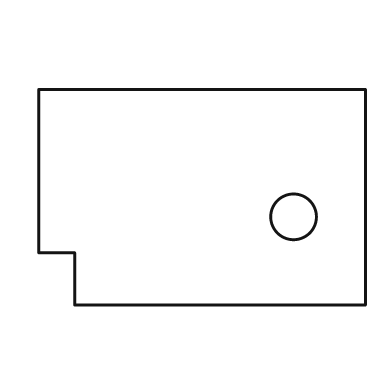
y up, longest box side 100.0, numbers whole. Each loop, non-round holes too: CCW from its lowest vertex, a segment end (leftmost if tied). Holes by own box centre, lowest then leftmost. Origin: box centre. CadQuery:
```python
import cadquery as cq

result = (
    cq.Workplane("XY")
    .moveTo(-39.0, -33.0)
    .lineTo(50.0, -33.0)
    .lineTo(50.0, 33.0)
    .lineTo(-50.0, 33.0)
    .lineTo(-50.0, -17.0)
    .lineTo(-39.0, -17.0)
    .close()
    .moveTo(28.0, -6.0)
    .circle(7.0)
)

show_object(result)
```